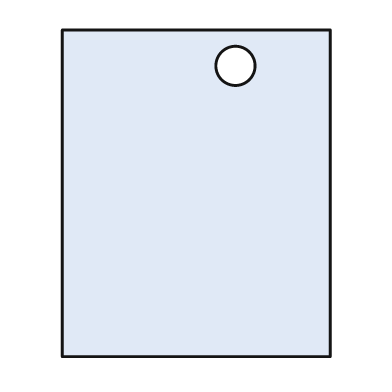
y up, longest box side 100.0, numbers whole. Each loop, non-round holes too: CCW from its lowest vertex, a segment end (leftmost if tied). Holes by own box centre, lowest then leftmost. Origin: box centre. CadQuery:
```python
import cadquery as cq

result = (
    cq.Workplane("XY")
    .moveTo(-41.0, -50.0)
    .lineTo(41.0, -50.0)
    .lineTo(41.0, 50.0)
    .lineTo(-41.0, 50.0)
    .close()
    .moveTo(12.0, 39.0)
    .circle(6.0)
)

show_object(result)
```